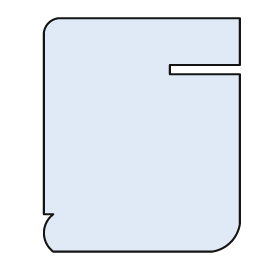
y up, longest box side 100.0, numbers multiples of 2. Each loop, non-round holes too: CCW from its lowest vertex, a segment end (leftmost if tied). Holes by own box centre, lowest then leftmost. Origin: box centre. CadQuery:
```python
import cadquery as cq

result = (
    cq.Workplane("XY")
    .moveTo(-38.0, -50.0)
    .lineTo(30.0, -50.0)
    .threePointArc((38.0, -46.0), (42.0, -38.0))
    .lineTo(42.0, 26.0)
    .lineTo(12.0, 26.0)
    .lineTo(12.0, 30.0)
    .lineTo(42.0, 30.0)
    .lineTo(42.0, 50.0)
    .lineTo(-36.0, 50.0)
    .threePointArc((-40.0, 48.0), (-42.0, 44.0))
    .lineTo(-42.0, -34.0)
    .lineTo(-38.0, -34.0)
    .threePointArc((-42.0, -42.0), (-38.0, -50.0))
    .close()
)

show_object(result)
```